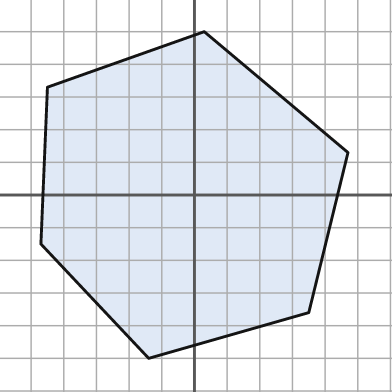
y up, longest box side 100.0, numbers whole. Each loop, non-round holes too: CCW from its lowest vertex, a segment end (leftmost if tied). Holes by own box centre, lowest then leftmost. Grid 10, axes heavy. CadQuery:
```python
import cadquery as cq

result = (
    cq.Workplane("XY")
    .moveTo(-14.0, -50.0)
    .lineTo(35.0, -36.0)
    .lineTo(47.0, 13.0)
    .lineTo(3.0, 50.0)
    .lineTo(-45.0, 33.0)
    .lineTo(-47.0, -15.0)
    .close()
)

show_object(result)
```